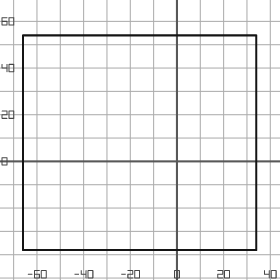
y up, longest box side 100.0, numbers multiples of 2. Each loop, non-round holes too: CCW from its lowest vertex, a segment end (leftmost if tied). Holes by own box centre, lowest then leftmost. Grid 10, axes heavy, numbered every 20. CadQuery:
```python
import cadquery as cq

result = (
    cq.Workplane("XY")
    .moveTo(-66.0, -38.0)
    .lineTo(34.0, -38.0)
    .lineTo(34.0, 54.0)
    .lineTo(-66.0, 54.0)
    .close()
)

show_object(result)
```